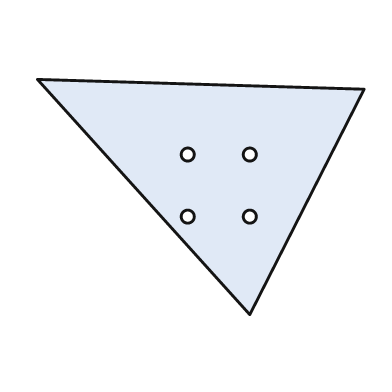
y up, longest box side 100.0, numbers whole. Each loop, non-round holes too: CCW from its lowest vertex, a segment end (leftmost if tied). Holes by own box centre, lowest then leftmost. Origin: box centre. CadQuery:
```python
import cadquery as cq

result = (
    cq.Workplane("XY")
    .moveTo(15.0, -36.0)
    .lineTo(50.0, 33.0)
    .lineTo(-50.0, 36.0)
    .close()
    .moveTo(-4.0, -6.0)
    .circle(2.0)
    .moveTo(15.0, -6.0)
    .circle(2.0)
    .moveTo(-4.0, 13.0)
    .circle(2.0)
    .moveTo(15.0, 13.0)
    .circle(2.0)
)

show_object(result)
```